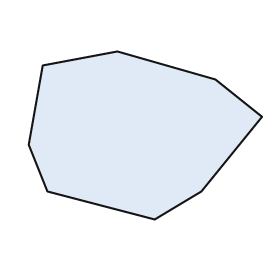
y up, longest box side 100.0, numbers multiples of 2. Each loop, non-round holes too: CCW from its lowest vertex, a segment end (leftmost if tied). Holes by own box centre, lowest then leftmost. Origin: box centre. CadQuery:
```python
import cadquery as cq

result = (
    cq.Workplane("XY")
    .moveTo(4.0, -36.0)
    .lineTo(24.0, -24.0)
    .lineTo(50.0, 8.0)
    .lineTo(30.0, 24.0)
    .lineTo(-12.0, 36.0)
    .lineTo(-44.0, 30.0)
    .lineTo(-50.0, -4.0)
    .lineTo(-42.0, -24.0)
    .close()
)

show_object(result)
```